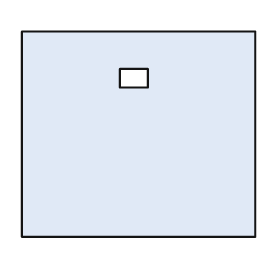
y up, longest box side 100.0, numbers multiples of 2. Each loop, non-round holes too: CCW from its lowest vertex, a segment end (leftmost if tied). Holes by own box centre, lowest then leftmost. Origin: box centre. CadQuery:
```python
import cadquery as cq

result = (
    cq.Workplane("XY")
    .moveTo(-50.0, -44.0)
    .lineTo(50.0, -44.0)
    .lineTo(50.0, 44.0)
    .lineTo(-50.0, 44.0)
    .close()
    .moveTo(-8.0, 20.0)
    .lineTo(4.0, 20.0)
    .lineTo(4.0, 28.0)
    .lineTo(-8.0, 28.0)
    .close()
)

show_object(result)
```